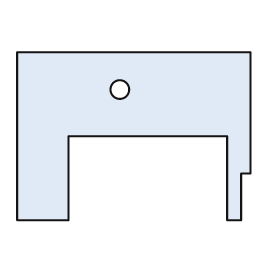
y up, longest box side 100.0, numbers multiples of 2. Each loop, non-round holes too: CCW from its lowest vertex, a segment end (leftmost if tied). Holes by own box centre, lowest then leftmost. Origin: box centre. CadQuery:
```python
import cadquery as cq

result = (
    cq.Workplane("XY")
    .moveTo(-50.0, -36.0)
    .lineTo(-28.0, -36.0)
    .lineTo(-28.0, 0.0)
    .lineTo(40.0, 0.0)
    .lineTo(40.0, -36.0)
    .lineTo(46.0, -36.0)
    .lineTo(46.0, -16.0)
    .lineTo(50.0, -16.0)
    .lineTo(50.0, 36.0)
    .lineTo(-50.0, 36.0)
    .close()
    .moveTo(-6.0, 20.0)
    .circle(4.0)
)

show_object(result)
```